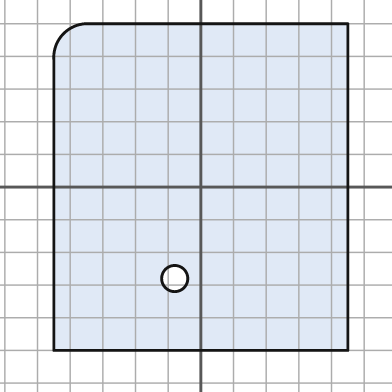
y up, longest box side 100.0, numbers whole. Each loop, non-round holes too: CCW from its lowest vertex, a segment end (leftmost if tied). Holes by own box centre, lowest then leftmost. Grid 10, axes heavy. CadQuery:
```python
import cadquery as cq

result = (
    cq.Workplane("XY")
    .moveTo(-45.0, -50.0)
    .lineTo(45.0, -50.0)
    .lineTo(45.0, 50.0)
    .lineTo(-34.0, 50.0)
    .threePointArc((-42.0, 47.0), (-45.0, 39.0))
    .close()
    .moveTo(-8.0, -28.0)
    .circle(4.0)
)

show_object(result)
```